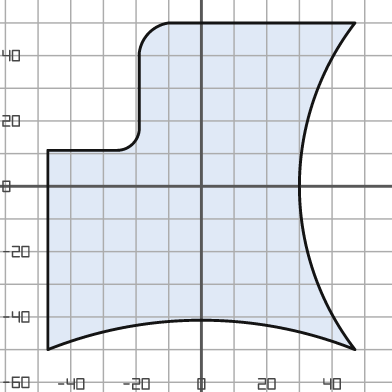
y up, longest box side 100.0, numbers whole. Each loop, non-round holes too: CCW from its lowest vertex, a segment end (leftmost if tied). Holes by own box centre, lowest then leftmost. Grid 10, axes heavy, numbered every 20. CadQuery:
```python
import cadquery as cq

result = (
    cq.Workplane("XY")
    .moveTo(-47.0, -50.0)
    .threePointArc((0.0, -41.0), (47.0, -50.0))
    .threePointArc((30.0, 0.0), (47.0, 50.0))
    .lineTo(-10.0, 50.0)
    .threePointArc((-16.0, 47.0), (-19.0, 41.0))
    .lineTo(-19.0, 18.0)
    .threePointArc((-21.0, 13.0), (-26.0, 11.0))
    .lineTo(-47.0, 11.0)
    .close()
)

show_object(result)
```